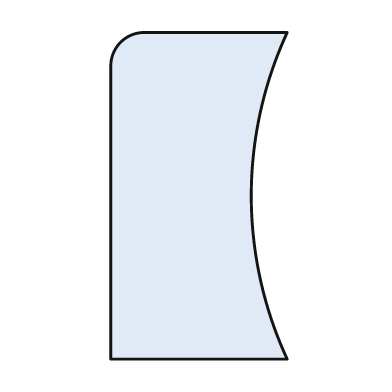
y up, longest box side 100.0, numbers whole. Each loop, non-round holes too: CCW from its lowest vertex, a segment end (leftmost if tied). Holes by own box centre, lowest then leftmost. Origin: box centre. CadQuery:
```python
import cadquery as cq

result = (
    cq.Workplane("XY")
    .moveTo(-27.0, -50.0)
    .lineTo(27.0, -50.0)
    .threePointArc((16.0, 0.0), (27.0, 50.0))
    .lineTo(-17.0, 50.0)
    .threePointArc((-24.0, 47.0), (-27.0, 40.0))
    .close()
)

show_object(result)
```